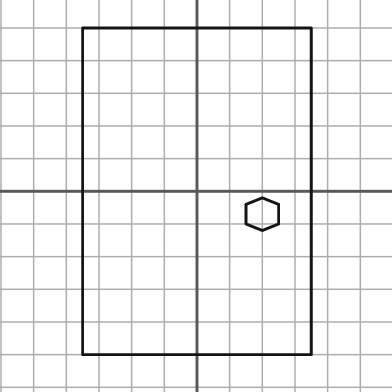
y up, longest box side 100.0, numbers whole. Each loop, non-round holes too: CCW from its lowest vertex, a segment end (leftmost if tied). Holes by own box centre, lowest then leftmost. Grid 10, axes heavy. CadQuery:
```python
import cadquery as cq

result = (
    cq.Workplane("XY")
    .moveTo(-35.0, -50.0)
    .lineTo(35.0, -50.0)
    .lineTo(35.0, 50.0)
    .lineTo(-35.0, 50.0)
    .close()
    .moveTo(20.0, -12.0)
    .lineTo(25.0, -10.0)
    .lineTo(25.0, -4.0)
    .lineTo(20.0, -2.0)
    .lineTo(15.0, -4.0)
    .lineTo(15.0, -10.0)
    .close()
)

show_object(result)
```